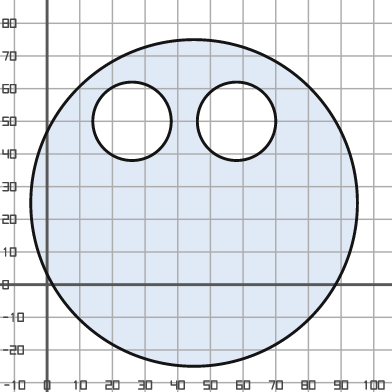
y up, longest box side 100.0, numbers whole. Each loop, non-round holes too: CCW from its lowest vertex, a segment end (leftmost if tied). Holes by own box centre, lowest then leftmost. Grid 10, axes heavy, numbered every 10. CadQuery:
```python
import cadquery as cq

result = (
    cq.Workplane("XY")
    .moveTo(45.0, 25.0)
    .circle(50.0)
    .moveTo(26.0, 50.0)
    .circle(12.0)
    .moveTo(58.0, 50.0)
    .circle(12.0)
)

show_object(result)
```